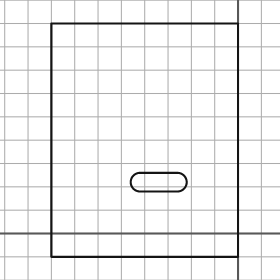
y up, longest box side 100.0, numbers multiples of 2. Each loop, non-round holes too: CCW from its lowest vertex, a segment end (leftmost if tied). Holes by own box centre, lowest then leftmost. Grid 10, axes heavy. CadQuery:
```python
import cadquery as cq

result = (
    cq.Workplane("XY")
    .moveTo(-80.0, -10.0)
    .lineTo(0.0, -10.0)
    .lineTo(0.0, 90.0)
    .lineTo(-80.0, 90.0)
    .close()
    .moveTo(-42.0, 18.0)
    .lineTo(-26.0, 18.0)
    .threePointArc((-22.0, 22.0), (-26.0, 26.0))
    .lineTo(-42.0, 26.0)
    .threePointArc((-46.0, 22.0), (-42.0, 18.0))
    .close()
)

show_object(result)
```